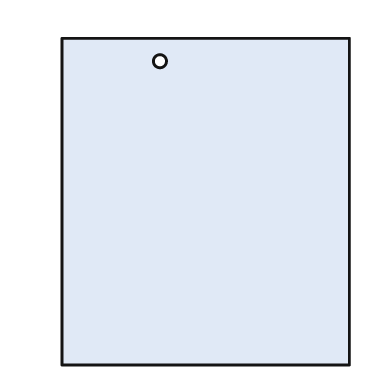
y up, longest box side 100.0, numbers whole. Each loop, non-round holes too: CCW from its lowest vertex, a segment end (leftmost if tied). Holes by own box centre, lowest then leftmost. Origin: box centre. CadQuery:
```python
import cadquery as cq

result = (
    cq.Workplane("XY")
    .moveTo(-44.0, -50.0)
    .lineTo(44.0, -50.0)
    .lineTo(44.0, 50.0)
    .lineTo(-44.0, 50.0)
    .close()
    .moveTo(-14.0, 43.0)
    .circle(2.0)
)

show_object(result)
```